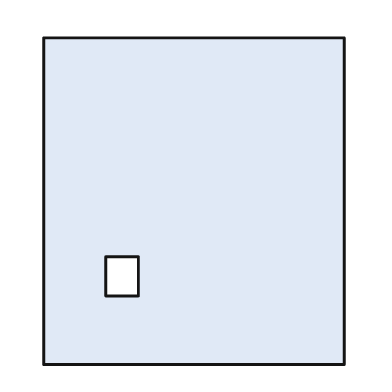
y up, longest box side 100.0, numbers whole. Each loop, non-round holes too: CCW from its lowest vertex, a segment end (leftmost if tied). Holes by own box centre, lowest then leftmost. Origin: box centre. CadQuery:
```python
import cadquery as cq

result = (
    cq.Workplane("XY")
    .moveTo(-46.0, -50.0)
    .lineTo(46.0, -50.0)
    .lineTo(46.0, 50.0)
    .lineTo(-46.0, 50.0)
    .close()
    .moveTo(-27.0, -29.0)
    .lineTo(-17.0, -29.0)
    .lineTo(-17.0, -17.0)
    .lineTo(-27.0, -17.0)
    .close()
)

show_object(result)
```